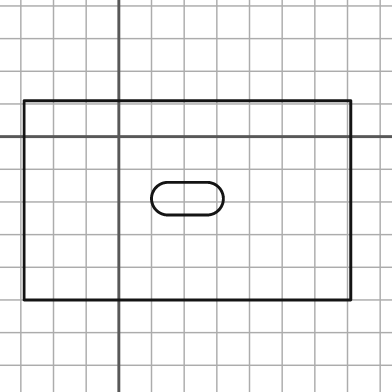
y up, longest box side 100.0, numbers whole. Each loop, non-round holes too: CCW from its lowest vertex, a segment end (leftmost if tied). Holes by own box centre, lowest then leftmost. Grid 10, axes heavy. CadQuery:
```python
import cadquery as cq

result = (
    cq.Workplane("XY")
    .moveTo(-29.0, -50.0)
    .lineTo(71.0, -50.0)
    .lineTo(71.0, 11.0)
    .lineTo(-29.0, 11.0)
    .close()
    .moveTo(15.0, -24.0)
    .lineTo(27.0, -24.0)
    .threePointArc((32.0, -19.0), (27.0, -14.0))
    .lineTo(15.0, -14.0)
    .threePointArc((10.0, -19.0), (15.0, -24.0))
    .close()
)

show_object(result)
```